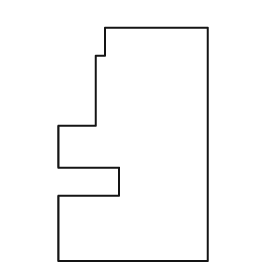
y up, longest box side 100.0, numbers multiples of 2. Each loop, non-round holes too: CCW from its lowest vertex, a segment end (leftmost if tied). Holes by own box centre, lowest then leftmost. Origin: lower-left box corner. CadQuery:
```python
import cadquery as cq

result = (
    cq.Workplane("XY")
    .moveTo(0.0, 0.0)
    .lineTo(64.0, 0.0)
    .lineTo(64.0, 100.0)
    .lineTo(20.0, 100.0)
    .lineTo(20.0, 88.0)
    .lineTo(16.0, 88.0)
    .lineTo(16.0, 58.0)
    .lineTo(0.0, 58.0)
    .lineTo(0.0, 40.0)
    .lineTo(26.0, 40.0)
    .lineTo(26.0, 28.0)
    .lineTo(0.0, 28.0)
    .close()
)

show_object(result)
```